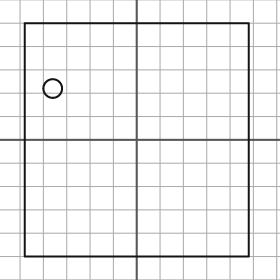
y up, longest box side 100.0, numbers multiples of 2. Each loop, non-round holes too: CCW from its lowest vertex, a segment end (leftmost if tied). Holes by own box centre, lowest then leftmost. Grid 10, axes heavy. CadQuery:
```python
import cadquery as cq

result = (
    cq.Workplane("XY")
    .moveTo(-48.0, -50.0)
    .lineTo(48.0, -50.0)
    .lineTo(48.0, 50.0)
    .lineTo(-48.0, 50.0)
    .close()
    .moveTo(-36.0, 22.0)
    .circle(4.0)
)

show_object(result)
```